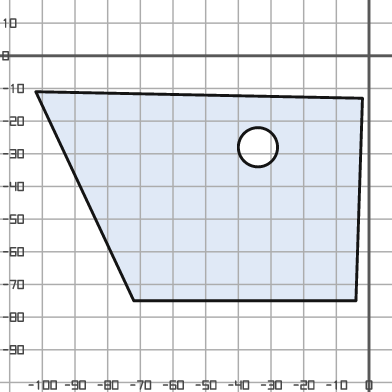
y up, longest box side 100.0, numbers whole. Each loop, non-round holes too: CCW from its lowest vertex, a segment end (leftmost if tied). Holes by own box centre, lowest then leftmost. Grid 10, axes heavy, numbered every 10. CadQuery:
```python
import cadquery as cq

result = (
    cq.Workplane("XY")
    .moveTo(-72.0, -75.0)
    .lineTo(-4.0, -75.0)
    .lineTo(-2.0, -13.0)
    .lineTo(-102.0, -11.0)
    .close()
    .moveTo(-34.0, -28.0)
    .circle(6.0)
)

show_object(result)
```